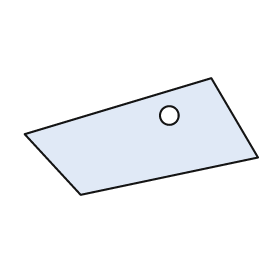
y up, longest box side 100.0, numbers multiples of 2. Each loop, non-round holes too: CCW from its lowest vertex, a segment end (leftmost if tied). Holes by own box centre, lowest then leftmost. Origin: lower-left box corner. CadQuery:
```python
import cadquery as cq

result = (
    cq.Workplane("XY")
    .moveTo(24.0, 0.0)
    .lineTo(100.0, 16.0)
    .lineTo(80.0, 50.0)
    .lineTo(0.0, 26.0)
    .close()
    .moveTo(62.0, 34.0)
    .circle(4.0)
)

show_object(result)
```